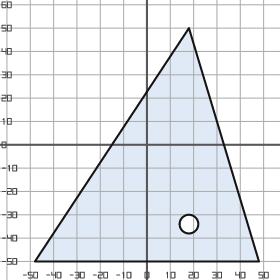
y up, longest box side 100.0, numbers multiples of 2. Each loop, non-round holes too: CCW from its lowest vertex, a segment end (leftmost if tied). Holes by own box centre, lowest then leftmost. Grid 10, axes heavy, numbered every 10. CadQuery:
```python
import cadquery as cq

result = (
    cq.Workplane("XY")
    .moveTo(-48.0, -50.0)
    .lineTo(48.0, -50.0)
    .lineTo(18.0, 50.0)
    .close()
    .moveTo(18.0, -34.0)
    .circle(4.0)
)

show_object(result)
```